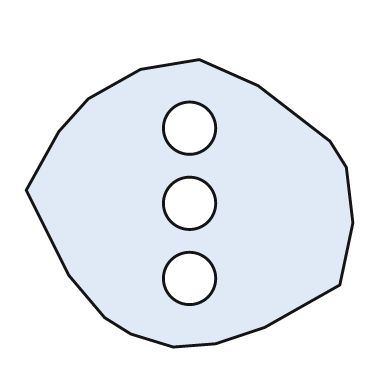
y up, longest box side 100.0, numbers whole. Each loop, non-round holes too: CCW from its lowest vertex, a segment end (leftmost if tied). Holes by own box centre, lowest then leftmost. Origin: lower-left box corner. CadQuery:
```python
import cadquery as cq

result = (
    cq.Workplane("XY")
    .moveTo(45.0, 0.0)
    .lineTo(58.0, 1.0)
    .lineTo(73.0, 6.0)
    .lineTo(96.0, 19.0)
    .lineTo(100.0, 38.0)
    .lineTo(98.0, 55.0)
    .lineTo(93.0, 63.0)
    .lineTo(71.0, 80.0)
    .lineTo(53.0, 88.0)
    .lineTo(35.0, 85.0)
    .lineTo(19.0, 76.0)
    .lineTo(10.0, 66.0)
    .lineTo(0.0, 48.0)
    .lineTo(13.0, 22.0)
    .lineTo(24.0, 9.0)
    .lineTo(32.0, 4.0)
    .close()
    .moveTo(50.0, 21.0)
    .circle(8.0)
    .moveTo(50.0, 44.0)
    .circle(8.0)
    .moveTo(50.0, 67.0)
    .circle(8.0)
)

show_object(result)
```